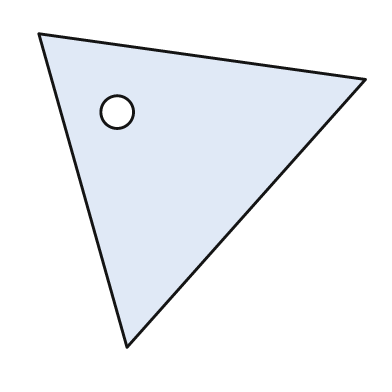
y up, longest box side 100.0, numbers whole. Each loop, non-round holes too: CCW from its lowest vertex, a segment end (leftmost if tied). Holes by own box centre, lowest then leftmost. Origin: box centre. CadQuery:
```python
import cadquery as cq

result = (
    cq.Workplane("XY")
    .moveTo(-23.0, -48.0)
    .lineTo(50.0, 34.0)
    .lineTo(-50.0, 48.0)
    .close()
    .moveTo(-26.0, 24.0)
    .circle(5.0)
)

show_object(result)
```